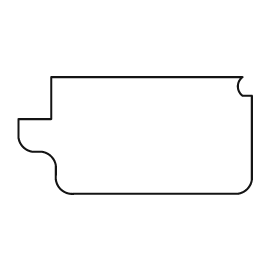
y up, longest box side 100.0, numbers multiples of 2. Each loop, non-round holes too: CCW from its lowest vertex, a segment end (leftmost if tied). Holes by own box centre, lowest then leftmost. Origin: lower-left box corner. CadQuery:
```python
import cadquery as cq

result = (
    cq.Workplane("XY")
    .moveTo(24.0, 0.0)
    .lineTo(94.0, 0.0)
    .threePointArc((98.0, 2.0), (100.0, 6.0))
    .lineTo(100.0, 42.0)
    .lineTo(96.0, 42.0)
    .threePointArc((94.0, 46.0), (96.0, 50.0))
    .lineTo(14.0, 50.0)
    .lineTo(14.0, 32.0)
    .lineTo(0.0, 32.0)
    .lineTo(0.0, 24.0)
    .threePointArc((2.0, 20.0), (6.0, 18.0))
    .lineTo(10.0, 18.0)
    .threePointArc((14.0, 16.0), (16.0, 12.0))
    .lineTo(16.0, 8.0)
    .threePointArc((18.0, 2.0), (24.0, 0.0))
    .close()
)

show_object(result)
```